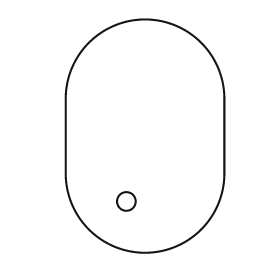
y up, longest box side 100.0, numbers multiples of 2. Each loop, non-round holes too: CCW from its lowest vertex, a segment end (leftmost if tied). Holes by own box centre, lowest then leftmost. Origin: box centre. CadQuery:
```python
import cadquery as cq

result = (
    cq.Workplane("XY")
    .moveTo(-34.0, -16.0)
    .threePointArc((0.0, -50.0), (34.0, -16.0))
    .lineTo(34.0, 16.0)
    .threePointArc((0.0, 50.0), (-34.0, 16.0))
    .close()
    .moveTo(-8.0, -28.0)
    .circle(4.0)
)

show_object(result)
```